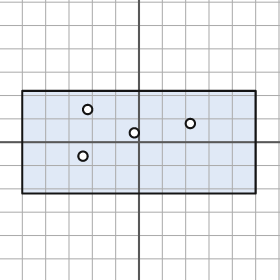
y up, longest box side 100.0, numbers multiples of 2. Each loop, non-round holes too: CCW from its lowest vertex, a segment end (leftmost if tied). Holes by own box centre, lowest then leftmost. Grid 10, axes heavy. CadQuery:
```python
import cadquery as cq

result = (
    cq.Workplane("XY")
    .moveTo(-50.0, -22.0)
    .lineTo(50.0, -22.0)
    .lineTo(50.0, 22.0)
    .lineTo(-50.0, 22.0)
    .close()
    .moveTo(-24.0, -6.0)
    .circle(2.0)
    .moveTo(-2.0, 4.0)
    .circle(2.0)
    .moveTo(22.0, 8.0)
    .circle(2.0)
    .moveTo(-22.0, 14.0)
    .circle(2.0)
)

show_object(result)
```